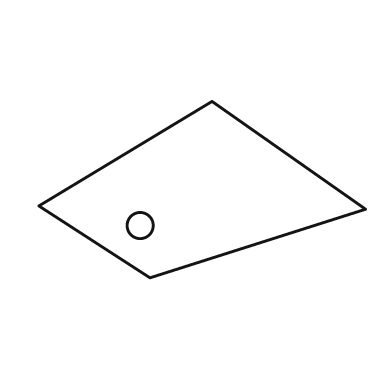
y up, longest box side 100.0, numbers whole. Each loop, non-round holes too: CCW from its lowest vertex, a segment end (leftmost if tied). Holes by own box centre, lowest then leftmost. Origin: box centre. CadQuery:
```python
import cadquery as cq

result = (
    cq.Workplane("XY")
    .moveTo(-16.0, -27.0)
    .lineTo(50.0, -6.0)
    .lineTo(3.0, 27.0)
    .lineTo(-50.0, -5.0)
    .close()
    .moveTo(-19.0, -11.0)
    .circle(4.0)
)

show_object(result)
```